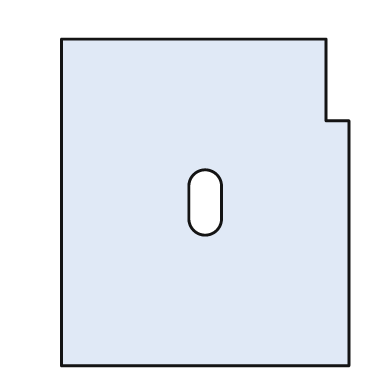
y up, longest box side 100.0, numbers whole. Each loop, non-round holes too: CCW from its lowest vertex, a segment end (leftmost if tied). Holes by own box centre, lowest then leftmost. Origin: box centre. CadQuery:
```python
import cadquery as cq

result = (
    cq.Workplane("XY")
    .moveTo(-44.0, -50.0)
    .lineTo(44.0, -50.0)
    .lineTo(44.0, 25.0)
    .lineTo(37.0, 25.0)
    .lineTo(37.0, 50.0)
    .lineTo(-44.0, 50.0)
    .close()
    .moveTo(-5.0, -5.0)
    .threePointArc((0.0, -10.0), (5.0, -5.0))
    .lineTo(5.0, 5.0)
    .threePointArc((0.0, 10.0), (-5.0, 5.0))
    .close()
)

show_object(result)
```